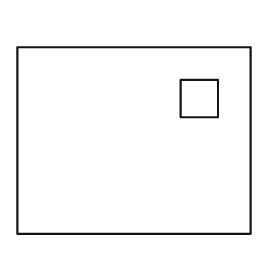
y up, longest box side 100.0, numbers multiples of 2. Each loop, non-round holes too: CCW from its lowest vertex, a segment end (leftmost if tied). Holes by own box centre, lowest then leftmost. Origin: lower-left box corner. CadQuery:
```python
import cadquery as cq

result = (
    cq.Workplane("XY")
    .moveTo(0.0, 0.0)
    .lineTo(100.0, 0.0)
    .lineTo(100.0, 80.0)
    .lineTo(0.0, 80.0)
    .close()
    .moveTo(70.0, 50.0)
    .lineTo(86.0, 50.0)
    .lineTo(86.0, 66.0)
    .lineTo(70.0, 66.0)
    .close()
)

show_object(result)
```